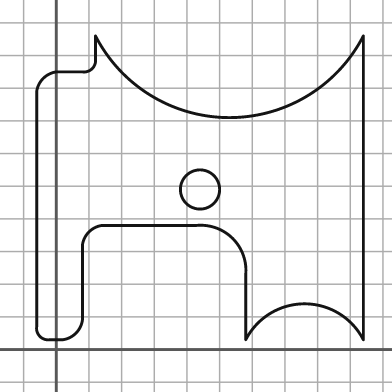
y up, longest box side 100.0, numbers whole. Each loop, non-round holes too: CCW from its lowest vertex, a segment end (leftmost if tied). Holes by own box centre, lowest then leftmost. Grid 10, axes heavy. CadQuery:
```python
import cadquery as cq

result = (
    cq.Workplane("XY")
    .moveTo(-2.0, 3.0)
    .lineTo(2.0, 3.0)
    .threePointArc((6.0, 5.0), (8.0, 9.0))
    .lineTo(8.0, 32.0)
    .threePointArc((10.0, 36.0), (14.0, 38.0))
    .lineTo(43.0, 38.0)
    .threePointArc((54.0, 34.0), (58.0, 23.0))
    .lineTo(58.0, 3.0)
    .threePointArc((76.0, 14.0), (94.0, 3.0))
    .lineTo(94.0, 96.0)
    .threePointArc((53.0, 71.0), (12.0, 96.0))
    .lineTo(12.0, 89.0)
    .threePointArc((11.0, 86.0), (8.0, 85.0))
    .lineTo(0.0, 85.0)
    .threePointArc((-4.0, 83.0), (-6.0, 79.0))
    .lineTo(-6.0, 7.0)
    .threePointArc((-5.0, 4.0), (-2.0, 3.0))
    .close()
    .moveTo(44.0, 49.0)
    .circle(6.0)
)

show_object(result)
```